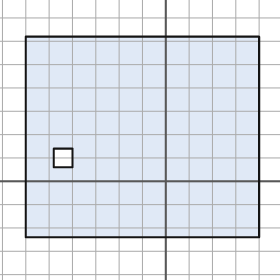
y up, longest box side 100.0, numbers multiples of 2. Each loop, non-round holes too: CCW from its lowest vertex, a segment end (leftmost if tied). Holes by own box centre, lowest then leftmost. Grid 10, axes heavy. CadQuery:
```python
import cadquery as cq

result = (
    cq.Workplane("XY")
    .moveTo(-60.0, -24.0)
    .lineTo(40.0, -24.0)
    .lineTo(40.0, 62.0)
    .lineTo(-60.0, 62.0)
    .close()
    .moveTo(-48.0, 6.0)
    .lineTo(-40.0, 6.0)
    .lineTo(-40.0, 14.0)
    .lineTo(-48.0, 14.0)
    .close()
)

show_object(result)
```